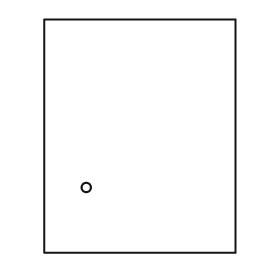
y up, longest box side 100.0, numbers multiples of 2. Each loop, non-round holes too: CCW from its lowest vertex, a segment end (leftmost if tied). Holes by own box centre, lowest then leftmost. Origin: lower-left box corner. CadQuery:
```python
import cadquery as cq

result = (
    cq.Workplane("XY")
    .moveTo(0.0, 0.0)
    .lineTo(82.0, 0.0)
    .lineTo(82.0, 100.0)
    .lineTo(0.0, 100.0)
    .close()
    .moveTo(18.0, 28.0)
    .circle(2.0)
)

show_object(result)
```